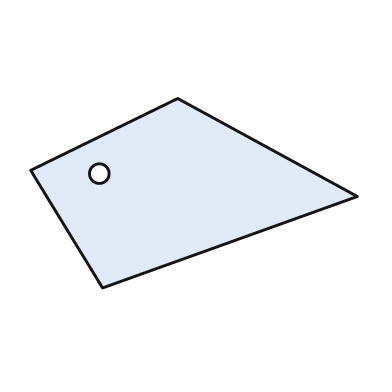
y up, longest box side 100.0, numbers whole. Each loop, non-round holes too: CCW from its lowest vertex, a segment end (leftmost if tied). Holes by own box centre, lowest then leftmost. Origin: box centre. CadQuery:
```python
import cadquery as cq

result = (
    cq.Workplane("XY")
    .moveTo(-28.0, -29.0)
    .lineTo(50.0, -1.0)
    .lineTo(-5.0, 29.0)
    .lineTo(-50.0, 7.0)
    .close()
    .moveTo(-29.0, 6.0)
    .circle(3.0)
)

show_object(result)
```